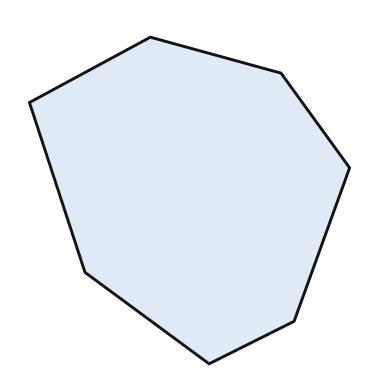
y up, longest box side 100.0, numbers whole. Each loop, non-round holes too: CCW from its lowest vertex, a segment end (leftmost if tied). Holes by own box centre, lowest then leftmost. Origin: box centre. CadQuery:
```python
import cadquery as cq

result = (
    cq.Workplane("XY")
    .moveTo(6.0, -50.0)
    .lineTo(32.0, -37.0)
    .lineTo(49.0, 10.0)
    .lineTo(28.0, 39.0)
    .lineTo(-12.0, 50.0)
    .lineTo(-49.0, 30.0)
    .lineTo(-32.0, -22.0)
    .close()
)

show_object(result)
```